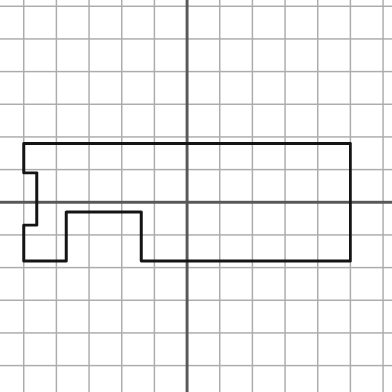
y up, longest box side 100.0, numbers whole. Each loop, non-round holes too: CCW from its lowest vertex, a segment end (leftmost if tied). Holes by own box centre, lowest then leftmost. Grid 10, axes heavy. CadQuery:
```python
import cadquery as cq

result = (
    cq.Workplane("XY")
    .moveTo(-50.0, -18.0)
    .lineTo(-37.0, -18.0)
    .lineTo(-37.0, -3.0)
    .lineTo(-14.0, -3.0)
    .lineTo(-14.0, -18.0)
    .lineTo(50.0, -18.0)
    .lineTo(50.0, 18.0)
    .lineTo(-50.0, 18.0)
    .lineTo(-50.0, 9.0)
    .lineTo(-46.0, 9.0)
    .lineTo(-46.0, -7.0)
    .lineTo(-50.0, -7.0)
    .close()
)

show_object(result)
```